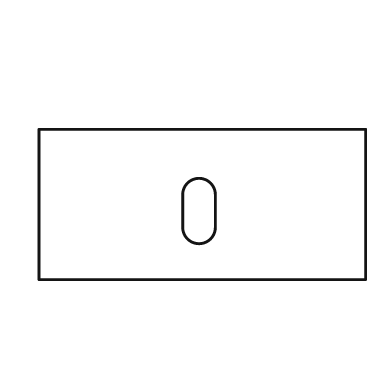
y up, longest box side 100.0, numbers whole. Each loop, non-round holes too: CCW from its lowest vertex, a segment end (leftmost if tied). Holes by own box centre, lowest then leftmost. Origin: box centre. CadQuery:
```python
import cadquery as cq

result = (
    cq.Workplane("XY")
    .moveTo(-50.0, -23.0)
    .lineTo(50.0, -23.0)
    .lineTo(50.0, 23.0)
    .lineTo(-50.0, 23.0)
    .close()
    .moveTo(-6.0, -7.0)
    .threePointArc((-1.0, -12.0), (4.0, -7.0))
    .lineTo(4.0, 3.0)
    .threePointArc((-1.0, 8.0), (-6.0, 3.0))
    .close()
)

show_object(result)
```